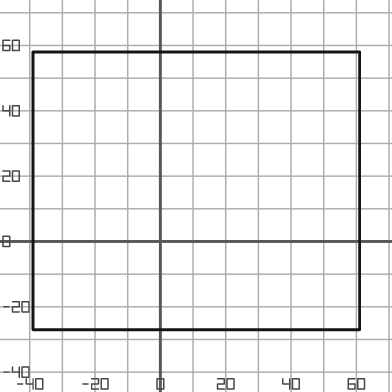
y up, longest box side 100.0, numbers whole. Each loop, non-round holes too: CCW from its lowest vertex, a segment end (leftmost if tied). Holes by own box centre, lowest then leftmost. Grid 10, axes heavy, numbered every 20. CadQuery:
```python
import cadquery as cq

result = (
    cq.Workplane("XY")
    .moveTo(-39.0, -27.0)
    .lineTo(61.0, -27.0)
    .lineTo(61.0, 58.0)
    .lineTo(-39.0, 58.0)
    .close()
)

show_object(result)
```